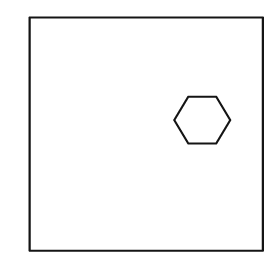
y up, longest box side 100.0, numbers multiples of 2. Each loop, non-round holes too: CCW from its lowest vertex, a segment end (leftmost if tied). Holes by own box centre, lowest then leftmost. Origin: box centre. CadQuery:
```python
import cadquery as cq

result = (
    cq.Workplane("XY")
    .moveTo(-50.0, -50.0)
    .lineTo(50.0, -50.0)
    .lineTo(50.0, 50.0)
    .lineTo(-50.0, 50.0)
    .close()
    .moveTo(18.0, -4.0)
    .lineTo(30.0, -4.0)
    .lineTo(36.0, 6.0)
    .lineTo(30.0, 16.0)
    .lineTo(18.0, 16.0)
    .lineTo(12.0, 6.0)
    .close()
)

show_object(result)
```